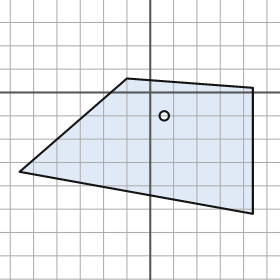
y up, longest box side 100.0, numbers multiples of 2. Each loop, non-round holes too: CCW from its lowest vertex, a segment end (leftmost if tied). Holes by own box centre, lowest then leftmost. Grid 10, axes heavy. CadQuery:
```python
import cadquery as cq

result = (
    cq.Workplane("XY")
    .moveTo(44.0, -52.0)
    .lineTo(44.0, 2.0)
    .lineTo(-10.0, 6.0)
    .lineTo(-56.0, -34.0)
    .close()
    .moveTo(6.0, -10.0)
    .circle(2.0)
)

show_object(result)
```